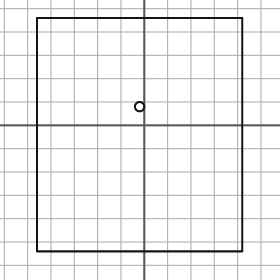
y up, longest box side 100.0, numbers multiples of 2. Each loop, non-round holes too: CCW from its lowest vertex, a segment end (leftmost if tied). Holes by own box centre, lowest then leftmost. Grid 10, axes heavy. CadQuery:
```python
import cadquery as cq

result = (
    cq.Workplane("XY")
    .moveTo(-46.0, -54.0)
    .lineTo(42.0, -54.0)
    .lineTo(42.0, 46.0)
    .lineTo(-46.0, 46.0)
    .close()
    .moveTo(-2.0, 8.0)
    .circle(2.0)
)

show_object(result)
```